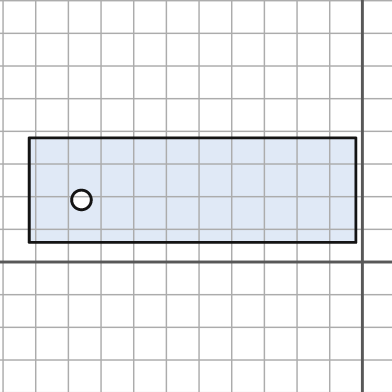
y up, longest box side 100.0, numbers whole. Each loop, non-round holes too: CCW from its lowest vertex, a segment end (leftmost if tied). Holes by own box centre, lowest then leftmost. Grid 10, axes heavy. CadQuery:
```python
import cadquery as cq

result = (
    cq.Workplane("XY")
    .moveTo(-102.0, 6.0)
    .lineTo(-2.0, 6.0)
    .lineTo(-2.0, 38.0)
    .lineTo(-102.0, 38.0)
    .close()
    .moveTo(-86.0, 19.0)
    .circle(3.0)
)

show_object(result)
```